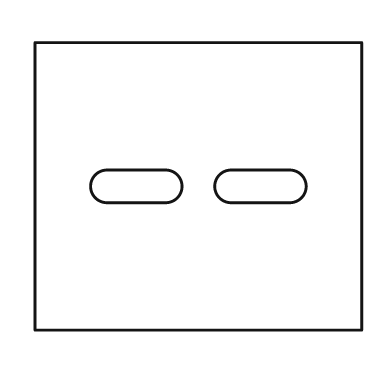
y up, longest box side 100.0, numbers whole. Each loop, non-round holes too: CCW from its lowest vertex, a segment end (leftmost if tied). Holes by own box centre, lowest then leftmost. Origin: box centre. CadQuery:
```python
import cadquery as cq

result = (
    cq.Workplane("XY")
    .moveTo(-50.0, -44.0)
    .lineTo(50.0, -44.0)
    .lineTo(50.0, 44.0)
    .lineTo(-50.0, 44.0)
    .close()
    .moveTo(-28.0, -5.0)
    .lineTo(-10.0, -5.0)
    .threePointArc((-5.0, 0.0), (-10.0, 5.0))
    .lineTo(-28.0, 5.0)
    .threePointArc((-33.0, 0.0), (-28.0, -5.0))
    .close()
    .moveTo(10.0, -5.0)
    .lineTo(28.0, -5.0)
    .threePointArc((33.0, 0.0), (28.0, 5.0))
    .lineTo(10.0, 5.0)
    .threePointArc((5.0, 0.0), (10.0, -5.0))
    .close()
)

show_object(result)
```